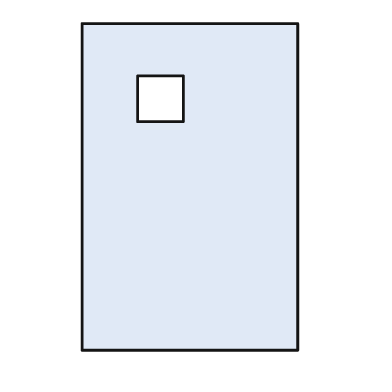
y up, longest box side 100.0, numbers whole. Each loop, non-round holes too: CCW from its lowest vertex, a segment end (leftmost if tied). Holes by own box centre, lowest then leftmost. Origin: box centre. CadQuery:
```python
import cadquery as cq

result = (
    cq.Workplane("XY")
    .moveTo(-33.0, -50.0)
    .lineTo(33.0, -50.0)
    .lineTo(33.0, 50.0)
    .lineTo(-33.0, 50.0)
    .close()
    .moveTo(-16.0, 20.0)
    .lineTo(-2.0, 20.0)
    .lineTo(-2.0, 34.0)
    .lineTo(-16.0, 34.0)
    .close()
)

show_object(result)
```